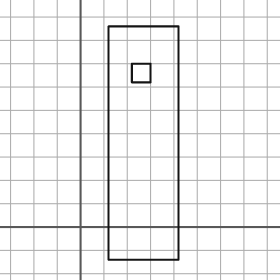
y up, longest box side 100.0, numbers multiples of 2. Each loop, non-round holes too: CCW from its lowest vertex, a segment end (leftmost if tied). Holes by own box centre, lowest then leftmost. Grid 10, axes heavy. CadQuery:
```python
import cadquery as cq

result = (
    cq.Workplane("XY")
    .moveTo(12.0, -14.0)
    .lineTo(42.0, -14.0)
    .lineTo(42.0, 86.0)
    .lineTo(12.0, 86.0)
    .close()
    .moveTo(22.0, 62.0)
    .lineTo(30.0, 62.0)
    .lineTo(30.0, 70.0)
    .lineTo(22.0, 70.0)
    .close()
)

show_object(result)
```